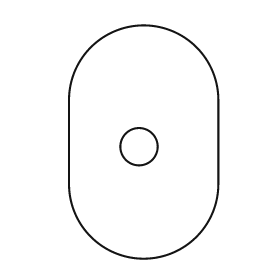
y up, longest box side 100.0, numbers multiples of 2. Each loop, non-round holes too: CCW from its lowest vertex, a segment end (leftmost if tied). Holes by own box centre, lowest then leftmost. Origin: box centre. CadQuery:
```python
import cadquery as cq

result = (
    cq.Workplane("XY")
    .moveTo(-32.0, -18.0)
    .threePointArc((0.0, -50.0), (32.0, -18.0))
    .lineTo(32.0, 18.0)
    .threePointArc((0.0, 50.0), (-32.0, 18.0))
    .close()
    .moveTo(-2.0, -2.0)
    .circle(8.0)
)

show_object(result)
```